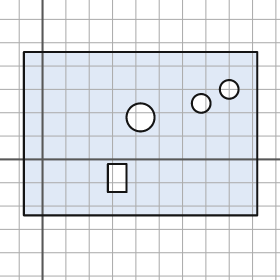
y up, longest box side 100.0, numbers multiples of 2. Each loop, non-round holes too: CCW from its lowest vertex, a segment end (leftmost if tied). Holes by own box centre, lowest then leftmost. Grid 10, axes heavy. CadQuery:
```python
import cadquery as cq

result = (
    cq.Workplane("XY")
    .moveTo(-8.0, -24.0)
    .lineTo(92.0, -24.0)
    .lineTo(92.0, 46.0)
    .lineTo(-8.0, 46.0)
    .close()
    .moveTo(28.0, -14.0)
    .lineTo(36.0, -14.0)
    .lineTo(36.0, -2.0)
    .lineTo(28.0, -2.0)
    .close()
    .moveTo(42.0, 18.0)
    .circle(6.0)
    .moveTo(68.0, 24.0)
    .circle(4.0)
    .moveTo(80.0, 30.0)
    .circle(4.0)
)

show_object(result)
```